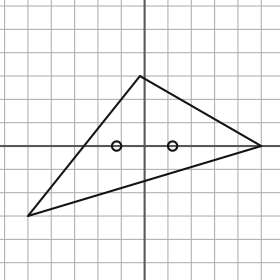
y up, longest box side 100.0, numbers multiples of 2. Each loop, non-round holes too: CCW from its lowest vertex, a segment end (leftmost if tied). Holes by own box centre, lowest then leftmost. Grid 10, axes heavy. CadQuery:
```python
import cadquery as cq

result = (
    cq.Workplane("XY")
    .moveTo(-50.0, -30.0)
    .lineTo(50.0, 0.0)
    .lineTo(-2.0, 30.0)
    .close()
    .moveTo(-12.0, 0.0)
    .circle(2.0)
    .moveTo(12.0, 0.0)
    .circle(2.0)
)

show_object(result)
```